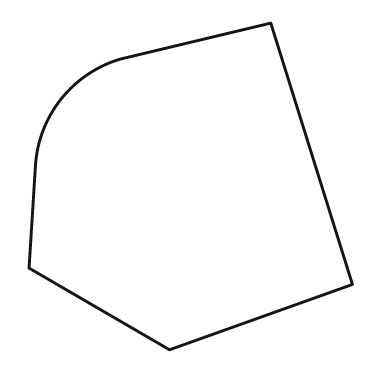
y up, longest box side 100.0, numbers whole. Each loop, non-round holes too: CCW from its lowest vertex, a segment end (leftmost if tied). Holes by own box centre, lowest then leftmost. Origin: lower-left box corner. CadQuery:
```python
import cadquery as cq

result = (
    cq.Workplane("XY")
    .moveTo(43.0, 0.0)
    .lineTo(99.0, 20.0)
    .lineTo(74.0, 100.0)
    .lineTo(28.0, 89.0)
    .threePointArc((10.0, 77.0), (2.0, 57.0))
    .lineTo(0.0, 25.0)
    .close()
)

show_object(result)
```